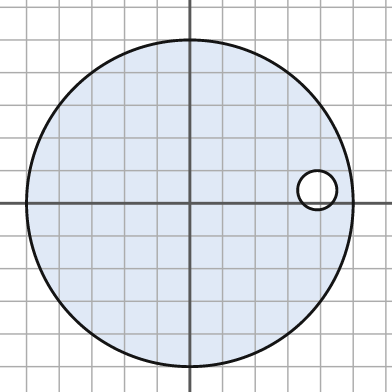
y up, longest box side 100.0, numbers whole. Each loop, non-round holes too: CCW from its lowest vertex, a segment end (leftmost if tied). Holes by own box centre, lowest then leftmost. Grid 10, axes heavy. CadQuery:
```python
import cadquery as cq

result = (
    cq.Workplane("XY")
    .moveTo(0.0, 0.0)
    .circle(50.0)
    .moveTo(39.0, 4.0)
    .circle(6.0)
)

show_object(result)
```